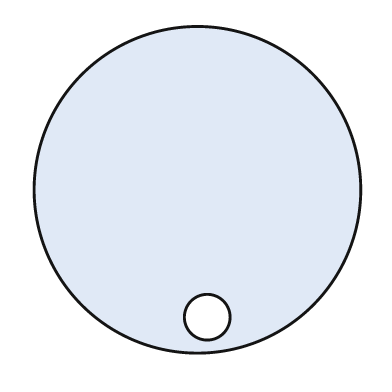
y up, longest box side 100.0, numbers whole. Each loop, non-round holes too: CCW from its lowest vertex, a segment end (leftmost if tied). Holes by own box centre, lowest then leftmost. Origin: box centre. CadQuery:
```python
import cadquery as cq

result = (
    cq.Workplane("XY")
    .moveTo(0.0, 0.0)
    .circle(50.0)
    .moveTo(3.0, -39.0)
    .circle(7.0)
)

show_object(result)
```